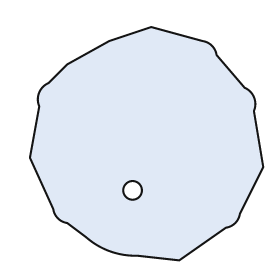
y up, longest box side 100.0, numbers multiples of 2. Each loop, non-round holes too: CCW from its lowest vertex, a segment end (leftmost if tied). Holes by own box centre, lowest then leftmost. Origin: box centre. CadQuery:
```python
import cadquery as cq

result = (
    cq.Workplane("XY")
    .moveTo(14.0, -50.0)
    .lineTo(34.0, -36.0)
    .threePointArc((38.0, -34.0), (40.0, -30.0))
    .lineTo(50.0, -10.0)
    .lineTo(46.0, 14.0)
    .threePointArc((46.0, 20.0), (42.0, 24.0))
    .lineTo(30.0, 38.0)
    .threePointArc((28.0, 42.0), (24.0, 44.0))
    .lineTo(2.0, 50.0)
    .lineTo(-16.0, 44.0)
    .lineTo(-34.0, 34.0)
    .lineTo(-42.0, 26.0)
    .threePointArc((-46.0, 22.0), (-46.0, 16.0))
    .lineTo(-50.0, -6.0)
    .lineTo(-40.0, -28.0)
    .threePointArc((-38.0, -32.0), (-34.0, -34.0))
    .lineTo(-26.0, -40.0)
    .threePointArc((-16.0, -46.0), (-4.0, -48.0))
    .close()
    .moveTo(-6.0, -20.0)
    .circle(4.0)
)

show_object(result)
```